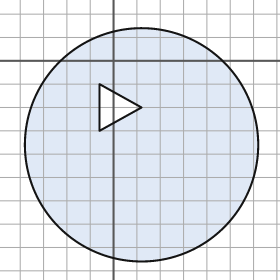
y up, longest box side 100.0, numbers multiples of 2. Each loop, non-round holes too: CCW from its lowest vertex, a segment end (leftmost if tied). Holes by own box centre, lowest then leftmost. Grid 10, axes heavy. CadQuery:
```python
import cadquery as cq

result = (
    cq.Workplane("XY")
    .moveTo(12.0, -36.0)
    .circle(50.0)
    .moveTo(-6.0, -30.0)
    .lineTo(12.0, -20.0)
    .lineTo(-6.0, -10.0)
    .close()
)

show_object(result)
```